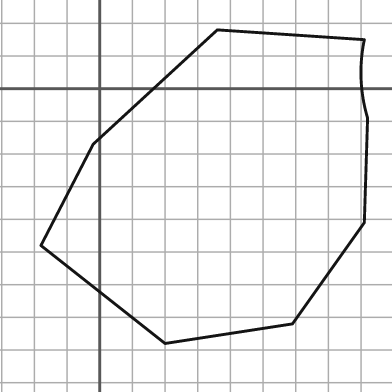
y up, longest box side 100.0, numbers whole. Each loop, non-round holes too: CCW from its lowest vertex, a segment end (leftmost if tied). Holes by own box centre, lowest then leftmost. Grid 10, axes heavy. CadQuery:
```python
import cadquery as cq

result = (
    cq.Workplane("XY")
    .moveTo(20.0, -78.0)
    .lineTo(59.0, -72.0)
    .lineTo(81.0, -41.0)
    .lineTo(82.0, -9.0)
    .threePointArc((80.0, 3.0), (81.0, 15.0))
    .lineTo(36.0, 18.0)
    .lineTo(-2.0, -17.0)
    .lineTo(-18.0, -48.0)
    .close()
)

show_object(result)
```